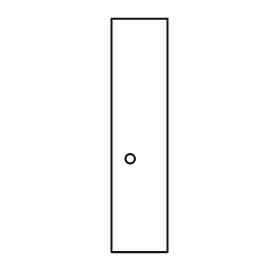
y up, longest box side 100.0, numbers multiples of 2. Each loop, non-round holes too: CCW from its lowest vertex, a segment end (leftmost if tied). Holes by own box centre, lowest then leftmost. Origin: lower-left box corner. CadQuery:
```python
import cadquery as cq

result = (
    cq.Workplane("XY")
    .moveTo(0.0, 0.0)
    .lineTo(24.0, 0.0)
    .lineTo(24.0, 100.0)
    .lineTo(0.0, 100.0)
    .close()
    .moveTo(8.0, 40.0)
    .circle(2.0)
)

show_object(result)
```